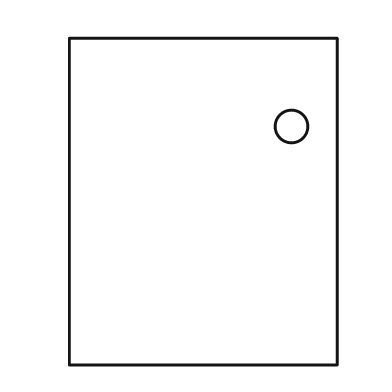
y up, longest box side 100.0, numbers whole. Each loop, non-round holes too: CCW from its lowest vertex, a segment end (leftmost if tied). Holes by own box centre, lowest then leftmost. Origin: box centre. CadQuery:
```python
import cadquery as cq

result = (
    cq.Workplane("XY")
    .moveTo(-41.0, -50.0)
    .lineTo(41.0, -50.0)
    .lineTo(41.0, 50.0)
    .lineTo(-41.0, 50.0)
    .close()
    .moveTo(27.0, 23.0)
    .circle(5.0)
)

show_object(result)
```